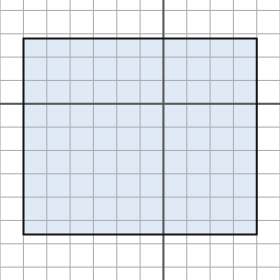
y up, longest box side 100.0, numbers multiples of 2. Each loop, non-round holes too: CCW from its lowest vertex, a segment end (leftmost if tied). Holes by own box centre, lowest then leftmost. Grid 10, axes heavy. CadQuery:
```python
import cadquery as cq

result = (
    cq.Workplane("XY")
    .moveTo(-60.0, -56.0)
    .lineTo(40.0, -56.0)
    .lineTo(40.0, 28.0)
    .lineTo(-60.0, 28.0)
    .close()
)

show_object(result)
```